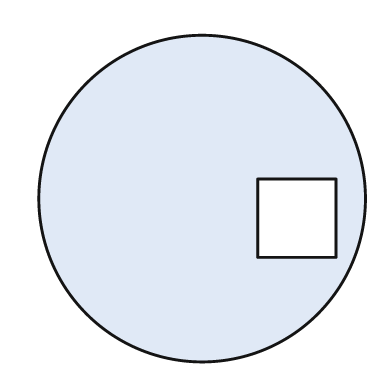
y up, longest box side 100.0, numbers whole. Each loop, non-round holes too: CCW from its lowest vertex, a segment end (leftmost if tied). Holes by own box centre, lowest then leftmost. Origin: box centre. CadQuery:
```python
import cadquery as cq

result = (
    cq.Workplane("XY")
    .moveTo(0.0, 0.0)
    .circle(50.0)
    .moveTo(17.0, -18.0)
    .lineTo(41.0, -18.0)
    .lineTo(41.0, 6.0)
    .lineTo(17.0, 6.0)
    .close()
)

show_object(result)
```